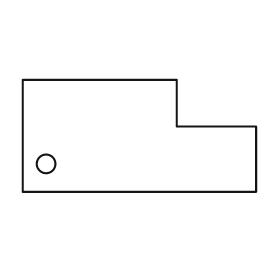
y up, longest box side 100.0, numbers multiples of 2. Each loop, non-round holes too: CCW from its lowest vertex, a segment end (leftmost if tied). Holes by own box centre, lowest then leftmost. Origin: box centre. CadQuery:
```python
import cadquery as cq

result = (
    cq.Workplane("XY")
    .moveTo(-50.0, -24.0)
    .lineTo(50.0, -24.0)
    .lineTo(50.0, 4.0)
    .lineTo(16.0, 4.0)
    .lineTo(16.0, 24.0)
    .lineTo(-50.0, 24.0)
    .close()
    .moveTo(-40.0, -12.0)
    .circle(4.0)
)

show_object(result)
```